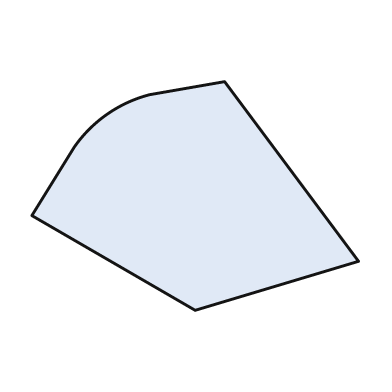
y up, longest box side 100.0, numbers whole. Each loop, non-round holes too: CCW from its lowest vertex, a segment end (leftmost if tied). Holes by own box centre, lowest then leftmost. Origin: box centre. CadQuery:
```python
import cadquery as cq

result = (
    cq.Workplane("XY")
    .moveTo(0.0, -35.0)
    .lineTo(50.0, -20.0)
    .lineTo(9.0, 35.0)
    .lineTo(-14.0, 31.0)
    .threePointArc((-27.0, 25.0), (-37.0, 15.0))
    .lineTo(-50.0, -6.0)
    .close()
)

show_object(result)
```